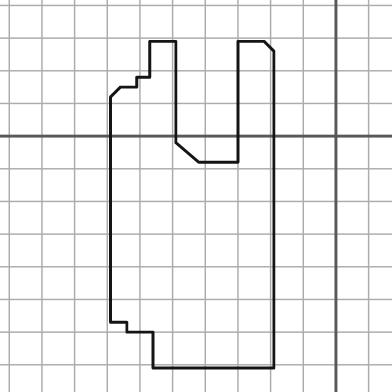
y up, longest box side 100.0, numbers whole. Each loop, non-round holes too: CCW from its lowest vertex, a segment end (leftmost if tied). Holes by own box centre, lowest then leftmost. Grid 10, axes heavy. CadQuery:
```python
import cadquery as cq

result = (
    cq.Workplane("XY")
    .moveTo(-56.0, -71.0)
    .lineTo(-19.0, -71.0)
    .lineTo(-19.0, 26.0)
    .lineTo(-22.0, 29.0)
    .lineTo(-30.0, 29.0)
    .lineTo(-30.0, -8.0)
    .lineTo(-42.0, -8.0)
    .lineTo(-49.0, -2.0)
    .lineTo(-49.0, 29.0)
    .lineTo(-57.0, 29.0)
    .lineTo(-57.0, 18.0)
    .lineTo(-61.0, 18.0)
    .lineTo(-61.0, 15.0)
    .lineTo(-66.0, 15.0)
    .lineTo(-69.0, 12.0)
    .lineTo(-69.0, -57.0)
    .lineTo(-64.0, -57.0)
    .lineTo(-64.0, -60.0)
    .lineTo(-56.0, -60.0)
    .close()
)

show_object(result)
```